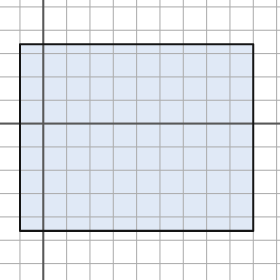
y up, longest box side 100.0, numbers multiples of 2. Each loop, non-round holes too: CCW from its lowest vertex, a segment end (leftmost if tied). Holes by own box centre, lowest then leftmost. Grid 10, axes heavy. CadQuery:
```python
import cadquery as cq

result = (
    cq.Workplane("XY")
    .moveTo(-10.0, -46.0)
    .lineTo(90.0, -46.0)
    .lineTo(90.0, 34.0)
    .lineTo(-10.0, 34.0)
    .close()
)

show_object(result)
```